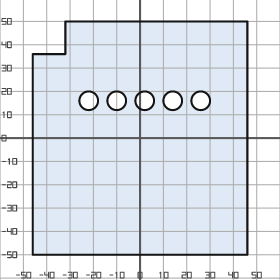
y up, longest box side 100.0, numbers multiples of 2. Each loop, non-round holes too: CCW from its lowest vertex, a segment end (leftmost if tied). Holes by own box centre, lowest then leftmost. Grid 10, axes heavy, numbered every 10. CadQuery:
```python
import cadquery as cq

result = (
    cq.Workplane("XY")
    .moveTo(-46.0, -50.0)
    .lineTo(46.0, -50.0)
    .lineTo(46.0, 50.0)
    .lineTo(-32.0, 50.0)
    .lineTo(-32.0, 36.0)
    .lineTo(-46.0, 36.0)
    .close()
    .moveTo(-22.0, 16.0)
    .circle(4.0)
    .moveTo(-10.0, 16.0)
    .circle(4.0)
    .moveTo(2.0, 16.0)
    .circle(4.0)
    .moveTo(14.0, 16.0)
    .circle(4.0)
    .moveTo(26.0, 16.0)
    .circle(4.0)
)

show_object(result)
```